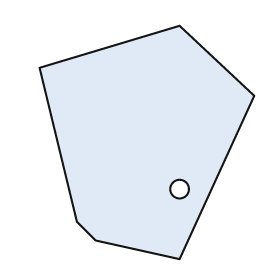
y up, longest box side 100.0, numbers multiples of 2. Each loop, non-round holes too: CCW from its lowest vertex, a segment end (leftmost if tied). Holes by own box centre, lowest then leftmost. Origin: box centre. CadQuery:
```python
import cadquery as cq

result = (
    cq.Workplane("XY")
    .moveTo(14.0, -50.0)
    .lineTo(46.0, 20.0)
    .lineTo(14.0, 50.0)
    .lineTo(-46.0, 32.0)
    .lineTo(-30.0, -34.0)
    .lineTo(-22.0, -42.0)
    .close()
    .moveTo(14.0, -20.0)
    .circle(4.0)
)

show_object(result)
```